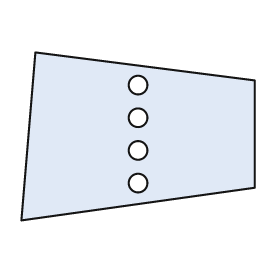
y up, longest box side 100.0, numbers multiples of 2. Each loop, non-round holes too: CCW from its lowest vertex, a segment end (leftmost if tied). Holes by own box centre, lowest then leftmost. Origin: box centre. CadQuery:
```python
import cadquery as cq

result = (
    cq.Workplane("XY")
    .moveTo(-50.0, -36.0)
    .lineTo(50.0, -22.0)
    .lineTo(50.0, 24.0)
    .lineTo(-44.0, 36.0)
    .close()
    .moveTo(0.0, -20.0)
    .circle(4.0)
    .moveTo(0.0, -6.0)
    .circle(4.0)
    .moveTo(0.0, 8.0)
    .circle(4.0)
    .moveTo(0.0, 22.0)
    .circle(4.0)
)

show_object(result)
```